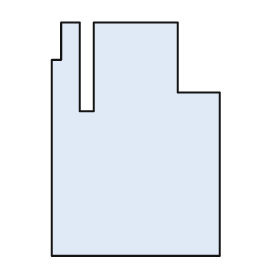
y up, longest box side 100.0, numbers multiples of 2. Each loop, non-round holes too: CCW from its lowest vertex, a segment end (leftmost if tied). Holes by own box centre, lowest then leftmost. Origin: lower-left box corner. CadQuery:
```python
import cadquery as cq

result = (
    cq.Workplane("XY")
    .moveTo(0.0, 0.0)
    .lineTo(72.0, 0.0)
    .lineTo(72.0, 70.0)
    .lineTo(54.0, 70.0)
    .lineTo(54.0, 100.0)
    .lineTo(18.0, 100.0)
    .lineTo(18.0, 62.0)
    .lineTo(12.0, 62.0)
    .lineTo(12.0, 100.0)
    .lineTo(4.0, 100.0)
    .lineTo(4.0, 84.0)
    .lineTo(0.0, 84.0)
    .close()
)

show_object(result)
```